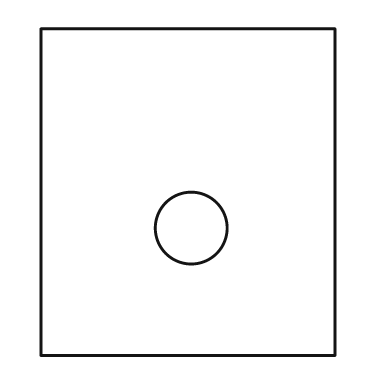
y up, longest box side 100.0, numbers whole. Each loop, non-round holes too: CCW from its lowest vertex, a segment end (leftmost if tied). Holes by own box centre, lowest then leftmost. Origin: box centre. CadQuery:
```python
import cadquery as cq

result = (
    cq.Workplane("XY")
    .moveTo(-45.0, -50.0)
    .lineTo(45.0, -50.0)
    .lineTo(45.0, 50.0)
    .lineTo(-45.0, 50.0)
    .close()
    .moveTo(1.0, -11.0)
    .circle(11.0)
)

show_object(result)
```